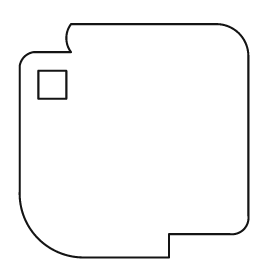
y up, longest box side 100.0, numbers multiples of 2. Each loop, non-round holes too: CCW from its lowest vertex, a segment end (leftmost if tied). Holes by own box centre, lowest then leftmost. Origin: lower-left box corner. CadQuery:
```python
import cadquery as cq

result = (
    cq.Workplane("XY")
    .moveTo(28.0, 0.0)
    .lineTo(64.0, 0.0)
    .lineTo(64.0, 10.0)
    .lineTo(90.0, 10.0)
    .threePointArc((96.0, 12.0), (98.0, 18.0))
    .lineTo(98.0, 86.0)
    .threePointArc((94.0, 96.0), (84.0, 100.0))
    .lineTo(22.0, 100.0)
    .threePointArc((20.0, 94.0), (22.0, 88.0))
    .lineTo(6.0, 88.0)
    .threePointArc((2.0, 86.0), (0.0, 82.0))
    .lineTo(0.0, 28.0)
    .threePointArc((8.0, 8.0), (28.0, 0.0))
    .close()
    .moveTo(8.0, 68.0)
    .lineTo(20.0, 68.0)
    .lineTo(20.0, 80.0)
    .lineTo(8.0, 80.0)
    .close()
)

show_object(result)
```